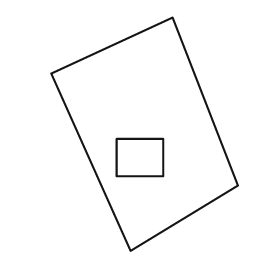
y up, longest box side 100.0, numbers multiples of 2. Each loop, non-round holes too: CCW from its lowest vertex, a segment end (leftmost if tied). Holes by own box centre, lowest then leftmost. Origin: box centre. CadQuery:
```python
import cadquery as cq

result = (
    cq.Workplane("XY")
    .moveTo(-6.0, -50.0)
    .lineTo(40.0, -22.0)
    .lineTo(12.0, 50.0)
    .lineTo(-40.0, 26.0)
    .close()
    .moveTo(-12.0, -18.0)
    .lineTo(8.0, -18.0)
    .lineTo(8.0, -2.0)
    .lineTo(-12.0, -2.0)
    .close()
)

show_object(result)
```